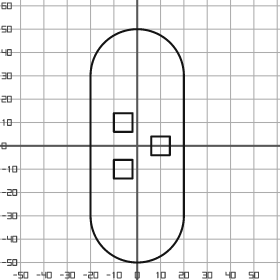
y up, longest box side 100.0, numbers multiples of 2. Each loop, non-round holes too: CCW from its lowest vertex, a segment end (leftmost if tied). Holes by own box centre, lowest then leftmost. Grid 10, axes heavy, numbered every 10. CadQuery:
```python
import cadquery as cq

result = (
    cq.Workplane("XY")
    .moveTo(-20.0, -30.0)
    .threePointArc((0.0, -50.0), (20.0, -30.0))
    .lineTo(20.0, 30.0)
    .threePointArc((0.0, 50.0), (-20.0, 30.0))
    .close()
    .moveTo(-10.0, -14.0)
    .lineTo(-2.0, -14.0)
    .lineTo(-2.0, -6.0)
    .lineTo(-10.0, -6.0)
    .close()
    .moveTo(6.0, -4.0)
    .lineTo(14.0, -4.0)
    .lineTo(14.0, 4.0)
    .lineTo(6.0, 4.0)
    .close()
    .moveTo(-10.0, 6.0)
    .lineTo(-2.0, 6.0)
    .lineTo(-2.0, 14.0)
    .lineTo(-10.0, 14.0)
    .close()
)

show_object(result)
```